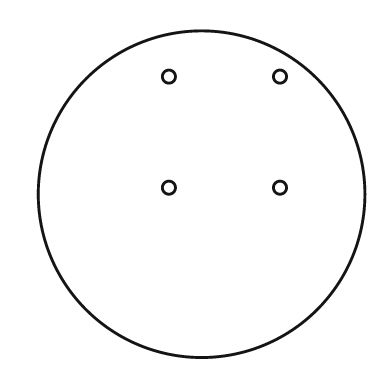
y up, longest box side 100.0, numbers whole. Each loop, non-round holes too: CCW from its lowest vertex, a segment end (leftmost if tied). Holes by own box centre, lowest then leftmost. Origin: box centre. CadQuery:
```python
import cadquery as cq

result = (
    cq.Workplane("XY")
    .moveTo(0.0, 0.0)
    .circle(50.0)
    .moveTo(-10.0, 2.0)
    .circle(2.0)
    .moveTo(24.0, 2.0)
    .circle(2.0)
    .moveTo(-10.0, 36.0)
    .circle(2.0)
    .moveTo(24.0, 36.0)
    .circle(2.0)
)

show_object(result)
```